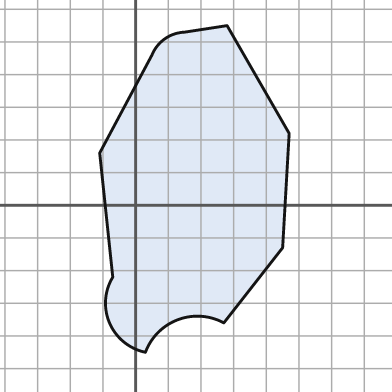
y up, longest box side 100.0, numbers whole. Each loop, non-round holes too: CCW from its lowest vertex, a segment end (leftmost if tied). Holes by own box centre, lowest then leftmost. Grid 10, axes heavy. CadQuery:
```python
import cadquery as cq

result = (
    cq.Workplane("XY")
    .moveTo(3.0, -45.0)
    .threePointArc((13.0, -35.0), (27.0, -36.0))
    .lineTo(45.0, -13.0)
    .lineTo(47.0, 22.0)
    .lineTo(28.0, 55.0)
    .lineTo(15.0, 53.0)
    .threePointArc((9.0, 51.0), (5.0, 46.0))
    .lineTo(-11.0, 16.0)
    .lineTo(-7.0, -22.0)
    .threePointArc((-8.0, -36.0), (3.0, -45.0))
    .close()
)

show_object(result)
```